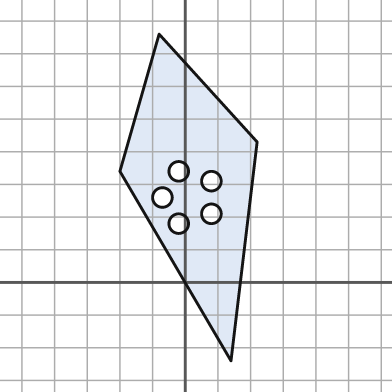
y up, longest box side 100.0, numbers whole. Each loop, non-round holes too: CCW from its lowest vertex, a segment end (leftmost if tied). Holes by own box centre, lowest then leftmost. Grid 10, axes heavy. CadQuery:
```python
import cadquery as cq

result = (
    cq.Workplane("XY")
    .moveTo(14.0, -24.0)
    .lineTo(22.0, 43.0)
    .lineTo(-8.0, 76.0)
    .lineTo(-20.0, 34.0)
    .close()
    .moveTo(-2.0, 18.0)
    .circle(3.0)
    .moveTo(8.0, 21.0)
    .circle(3.0)
    .moveTo(-7.0, 26.0)
    .circle(3.0)
    .moveTo(8.0, 31.0)
    .circle(3.0)
    .moveTo(-2.0, 34.0)
    .circle(3.0)
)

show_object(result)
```